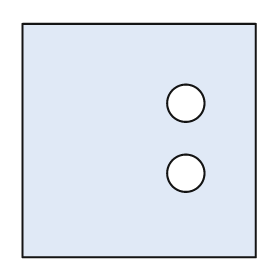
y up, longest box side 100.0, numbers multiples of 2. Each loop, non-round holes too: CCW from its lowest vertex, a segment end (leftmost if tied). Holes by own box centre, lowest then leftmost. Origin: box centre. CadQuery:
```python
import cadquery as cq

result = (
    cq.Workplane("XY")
    .moveTo(-50.0, -50.0)
    .lineTo(50.0, -50.0)
    .lineTo(50.0, 50.0)
    .lineTo(-50.0, 50.0)
    .close()
    .moveTo(20.0, -14.0)
    .circle(8.0)
    .moveTo(20.0, 16.0)
    .circle(8.0)
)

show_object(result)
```